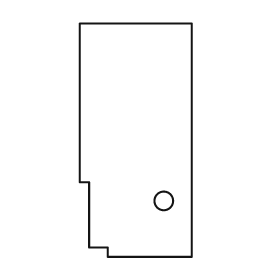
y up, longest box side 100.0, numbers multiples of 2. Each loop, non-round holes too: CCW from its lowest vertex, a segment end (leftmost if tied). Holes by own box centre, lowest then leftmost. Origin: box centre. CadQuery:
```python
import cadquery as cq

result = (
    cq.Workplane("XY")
    .moveTo(-12.0, -50.0)
    .lineTo(24.0, -50.0)
    .lineTo(24.0, 50.0)
    .lineTo(-24.0, 50.0)
    .lineTo(-24.0, -18.0)
    .lineTo(-20.0, -18.0)
    .lineTo(-20.0, -46.0)
    .lineTo(-12.0, -46.0)
    .close()
    .moveTo(12.0, -26.0)
    .circle(4.0)
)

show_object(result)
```